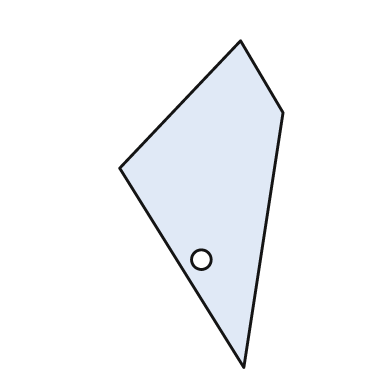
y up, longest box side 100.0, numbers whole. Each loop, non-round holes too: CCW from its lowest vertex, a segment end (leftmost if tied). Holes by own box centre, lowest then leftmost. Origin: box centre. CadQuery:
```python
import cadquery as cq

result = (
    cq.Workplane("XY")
    .moveTo(13.0, -50.0)
    .lineTo(25.0, 28.0)
    .lineTo(12.0, 50.0)
    .lineTo(-25.0, 11.0)
    .close()
    .moveTo(0.0, -17.0)
    .circle(3.0)
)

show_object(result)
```